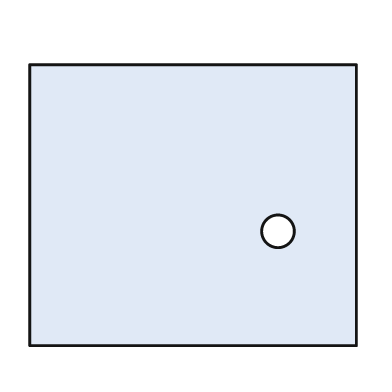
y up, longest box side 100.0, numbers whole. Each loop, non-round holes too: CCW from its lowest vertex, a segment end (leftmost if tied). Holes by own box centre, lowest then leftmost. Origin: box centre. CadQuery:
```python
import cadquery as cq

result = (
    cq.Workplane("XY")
    .moveTo(-50.0, -43.0)
    .lineTo(50.0, -43.0)
    .lineTo(50.0, 43.0)
    .lineTo(-50.0, 43.0)
    .close()
    .moveTo(26.0, -8.0)
    .circle(5.0)
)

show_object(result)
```